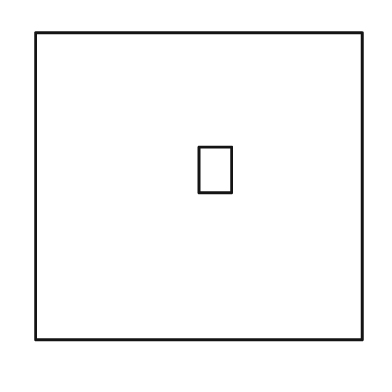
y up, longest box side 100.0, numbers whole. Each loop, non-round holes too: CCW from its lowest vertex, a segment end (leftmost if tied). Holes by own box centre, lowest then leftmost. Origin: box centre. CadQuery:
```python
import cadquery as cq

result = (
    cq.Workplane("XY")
    .moveTo(-50.0, -47.0)
    .lineTo(50.0, -47.0)
    .lineTo(50.0, 47.0)
    .lineTo(-50.0, 47.0)
    .close()
    .moveTo(0.0, -2.0)
    .lineTo(10.0, -2.0)
    .lineTo(10.0, 12.0)
    .lineTo(0.0, 12.0)
    .close()
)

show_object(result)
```